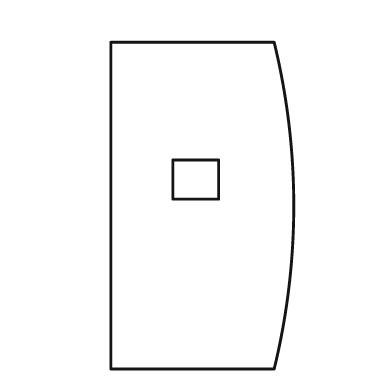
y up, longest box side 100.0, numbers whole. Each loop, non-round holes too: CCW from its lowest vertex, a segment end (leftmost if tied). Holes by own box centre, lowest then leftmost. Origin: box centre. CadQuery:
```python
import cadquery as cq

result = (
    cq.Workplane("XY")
    .moveTo(-28.0, -50.0)
    .lineTo(22.0, -50.0)
    .threePointArc((28.0, 0.0), (22.0, 50.0))
    .lineTo(-28.0, 50.0)
    .close()
    .moveTo(-9.0, 2.0)
    .lineTo(5.0, 2.0)
    .lineTo(5.0, 14.0)
    .lineTo(-9.0, 14.0)
    .close()
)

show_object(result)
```